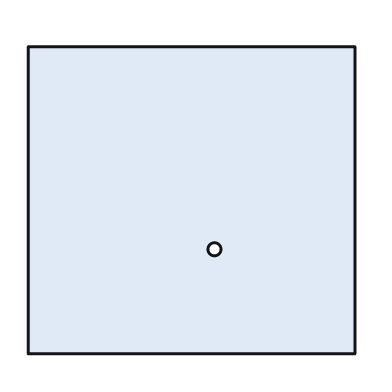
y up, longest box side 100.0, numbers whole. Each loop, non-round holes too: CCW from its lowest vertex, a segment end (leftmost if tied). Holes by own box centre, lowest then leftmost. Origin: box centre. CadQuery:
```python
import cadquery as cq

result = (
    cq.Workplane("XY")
    .moveTo(-50.0, -47.0)
    .lineTo(50.0, -47.0)
    .lineTo(50.0, 47.0)
    .lineTo(-50.0, 47.0)
    .close()
    .moveTo(7.0, -15.0)
    .circle(2.0)
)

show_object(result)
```